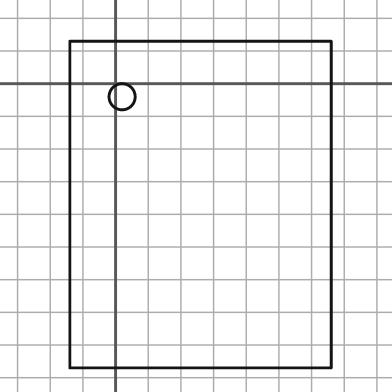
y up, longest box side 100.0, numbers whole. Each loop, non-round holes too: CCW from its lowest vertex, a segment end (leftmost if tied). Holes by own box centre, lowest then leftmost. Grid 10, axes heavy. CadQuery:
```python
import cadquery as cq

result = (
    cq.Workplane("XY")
    .moveTo(-14.0, -87.0)
    .lineTo(66.0, -87.0)
    .lineTo(66.0, 13.0)
    .lineTo(-14.0, 13.0)
    .close()
    .moveTo(2.0, -4.0)
    .circle(4.0)
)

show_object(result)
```